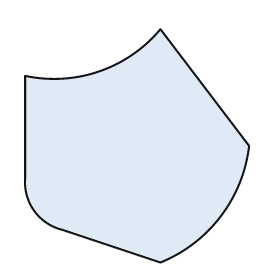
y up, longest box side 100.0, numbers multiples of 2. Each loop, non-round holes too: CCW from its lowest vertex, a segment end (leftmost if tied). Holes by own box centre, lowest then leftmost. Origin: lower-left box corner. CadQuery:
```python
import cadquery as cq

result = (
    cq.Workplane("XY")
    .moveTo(58.0, 0.0)
    .threePointArc((84.0, 20.0), (96.0, 50.0))
    .lineTo(58.0, 100.0)
    .threePointArc((32.0, 82.0), (0.0, 80.0))
    .lineTo(0.0, 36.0)
    .threePointArc((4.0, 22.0), (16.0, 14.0))
    .close()
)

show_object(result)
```